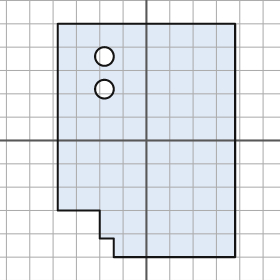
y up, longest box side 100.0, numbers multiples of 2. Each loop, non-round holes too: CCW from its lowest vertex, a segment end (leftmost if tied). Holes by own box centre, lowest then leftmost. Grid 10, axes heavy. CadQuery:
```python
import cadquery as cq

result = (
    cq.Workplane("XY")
    .moveTo(-14.0, -50.0)
    .lineTo(38.0, -50.0)
    .lineTo(38.0, 50.0)
    .lineTo(-38.0, 50.0)
    .lineTo(-38.0, -30.0)
    .lineTo(-20.0, -30.0)
    .lineTo(-20.0, -42.0)
    .lineTo(-14.0, -42.0)
    .close()
    .moveTo(-18.0, 22.0)
    .circle(4.0)
    .moveTo(-18.0, 36.0)
    .circle(4.0)
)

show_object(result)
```